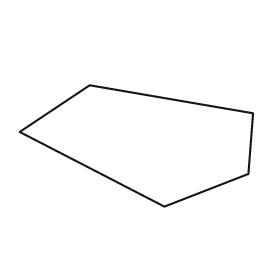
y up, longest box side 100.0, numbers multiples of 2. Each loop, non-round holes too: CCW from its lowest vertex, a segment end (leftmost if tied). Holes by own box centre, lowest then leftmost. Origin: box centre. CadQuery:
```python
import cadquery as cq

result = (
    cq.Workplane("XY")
    .moveTo(12.0, -26.0)
    .lineTo(48.0, -12.0)
    .lineTo(50.0, 14.0)
    .lineTo(-20.0, 26.0)
    .lineTo(-50.0, 6.0)
    .close()
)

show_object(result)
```